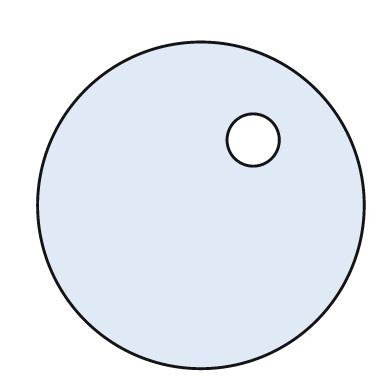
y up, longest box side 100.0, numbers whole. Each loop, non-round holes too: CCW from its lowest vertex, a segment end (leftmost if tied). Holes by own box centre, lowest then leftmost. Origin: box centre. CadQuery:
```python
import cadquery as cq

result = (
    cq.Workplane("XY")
    .moveTo(0.0, 0.0)
    .circle(50.0)
    .moveTo(16.0, 20.0)
    .circle(8.0)
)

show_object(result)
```